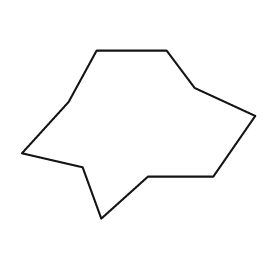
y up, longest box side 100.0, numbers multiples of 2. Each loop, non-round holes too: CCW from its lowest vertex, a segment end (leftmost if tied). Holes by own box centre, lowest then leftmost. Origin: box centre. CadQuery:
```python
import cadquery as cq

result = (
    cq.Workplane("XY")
    .moveTo(-16.0, -36.0)
    .lineTo(4.0, -18.0)
    .lineTo(32.0, -18.0)
    .lineTo(50.0, 8.0)
    .lineTo(24.0, 20.0)
    .lineTo(12.0, 36.0)
    .lineTo(-18.0, 36.0)
    .lineTo(-30.0, 14.0)
    .lineTo(-50.0, -8.0)
    .lineTo(-24.0, -14.0)
    .close()
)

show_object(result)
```